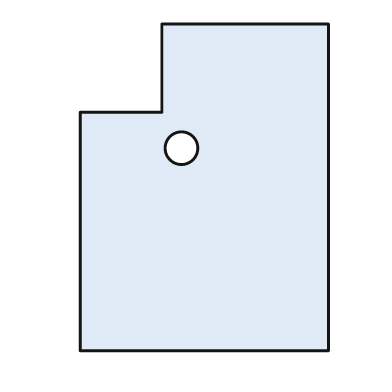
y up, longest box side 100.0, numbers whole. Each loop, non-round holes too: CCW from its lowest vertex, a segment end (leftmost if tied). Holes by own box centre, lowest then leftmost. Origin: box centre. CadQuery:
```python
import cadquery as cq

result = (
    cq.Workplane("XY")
    .moveTo(-38.0, -50.0)
    .lineTo(38.0, -50.0)
    .lineTo(38.0, 50.0)
    .lineTo(-13.0, 50.0)
    .lineTo(-13.0, 23.0)
    .lineTo(-38.0, 23.0)
    .close()
    .moveTo(-7.0, 12.0)
    .circle(5.0)
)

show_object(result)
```